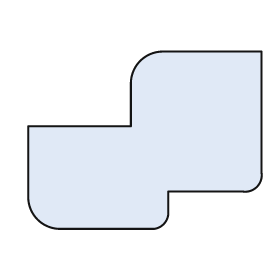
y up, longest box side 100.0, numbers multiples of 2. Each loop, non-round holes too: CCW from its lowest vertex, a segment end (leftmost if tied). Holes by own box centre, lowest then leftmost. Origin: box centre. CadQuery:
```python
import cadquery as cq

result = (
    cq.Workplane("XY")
    .moveTo(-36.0, -38.0)
    .lineTo(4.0, -38.0)
    .threePointArc((8.0, -36.0), (10.0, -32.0))
    .lineTo(10.0, -22.0)
    .lineTo(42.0, -22.0)
    .threePointArc((48.0, -20.0), (50.0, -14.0))
    .lineTo(50.0, 38.0)
    .lineTo(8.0, 38.0)
    .threePointArc((-2.0, 34.0), (-6.0, 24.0))
    .lineTo(-6.0, 6.0)
    .lineTo(-50.0, 6.0)
    .lineTo(-50.0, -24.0)
    .threePointArc((-46.0, -34.0), (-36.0, -38.0))
    .close()
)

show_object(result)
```